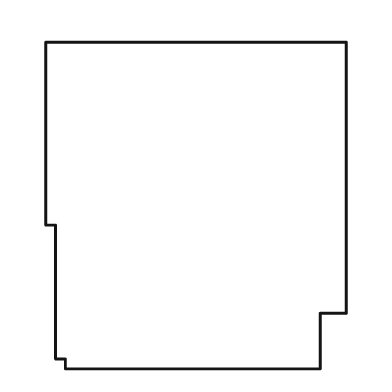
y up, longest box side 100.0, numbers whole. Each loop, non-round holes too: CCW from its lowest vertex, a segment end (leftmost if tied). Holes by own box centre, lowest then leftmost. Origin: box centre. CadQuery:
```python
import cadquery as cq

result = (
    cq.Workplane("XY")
    .moveTo(-40.0, -50.0)
    .lineTo(38.0, -50.0)
    .lineTo(38.0, -33.0)
    .lineTo(46.0, -33.0)
    .lineTo(46.0, 50.0)
    .lineTo(-46.0, 50.0)
    .lineTo(-46.0, -6.0)
    .lineTo(-43.0, -6.0)
    .lineTo(-43.0, -47.0)
    .lineTo(-40.0, -47.0)
    .close()
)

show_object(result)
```